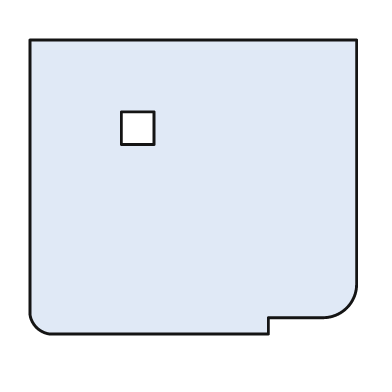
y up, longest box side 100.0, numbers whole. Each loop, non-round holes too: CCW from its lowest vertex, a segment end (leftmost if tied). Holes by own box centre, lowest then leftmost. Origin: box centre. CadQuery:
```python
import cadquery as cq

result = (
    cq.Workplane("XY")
    .moveTo(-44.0, -45.0)
    .lineTo(23.0, -45.0)
    .lineTo(23.0, -40.0)
    .lineTo(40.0, -40.0)
    .threePointArc((47.0, -37.0), (50.0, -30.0))
    .lineTo(50.0, 45.0)
    .lineTo(-50.0, 45.0)
    .lineTo(-50.0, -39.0)
    .threePointArc((-48.0, -43.0), (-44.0, -45.0))
    .close()
    .moveTo(-22.0, 13.0)
    .lineTo(-12.0, 13.0)
    .lineTo(-12.0, 23.0)
    .lineTo(-22.0, 23.0)
    .close()
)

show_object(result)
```